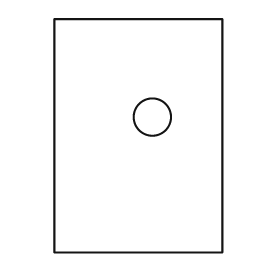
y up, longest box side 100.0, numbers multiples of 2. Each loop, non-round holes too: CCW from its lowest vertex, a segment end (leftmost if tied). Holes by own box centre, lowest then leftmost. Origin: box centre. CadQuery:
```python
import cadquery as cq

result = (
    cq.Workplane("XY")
    .moveTo(-36.0, -50.0)
    .lineTo(36.0, -50.0)
    .lineTo(36.0, 50.0)
    .lineTo(-36.0, 50.0)
    .close()
    .moveTo(6.0, 8.0)
    .circle(8.0)
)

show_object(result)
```